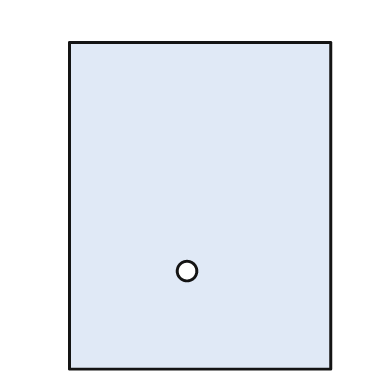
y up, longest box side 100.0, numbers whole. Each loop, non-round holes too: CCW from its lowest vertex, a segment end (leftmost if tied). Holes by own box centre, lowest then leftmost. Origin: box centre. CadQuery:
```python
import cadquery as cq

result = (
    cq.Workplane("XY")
    .moveTo(-40.0, -50.0)
    .lineTo(40.0, -50.0)
    .lineTo(40.0, 50.0)
    .lineTo(-40.0, 50.0)
    .close()
    .moveTo(-4.0, -20.0)
    .circle(3.0)
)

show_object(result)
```